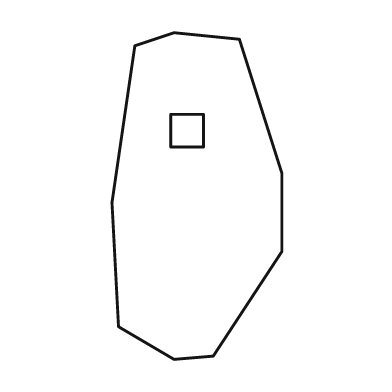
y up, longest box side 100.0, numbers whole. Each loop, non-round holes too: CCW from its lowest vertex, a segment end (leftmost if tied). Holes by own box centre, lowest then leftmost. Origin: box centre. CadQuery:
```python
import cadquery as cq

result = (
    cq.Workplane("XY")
    .moveTo(-7.0, -50.0)
    .lineTo(5.0, -49.0)
    .lineTo(26.0, -17.0)
    .lineTo(26.0, 7.0)
    .lineTo(13.0, 48.0)
    .lineTo(-7.0, 50.0)
    .lineTo(-19.0, 46.0)
    .lineTo(-26.0, -2.0)
    .lineTo(-24.0, -40.0)
    .close()
    .moveTo(-8.0, 15.0)
    .lineTo(2.0, 15.0)
    .lineTo(2.0, 25.0)
    .lineTo(-8.0, 25.0)
    .close()
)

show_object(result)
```